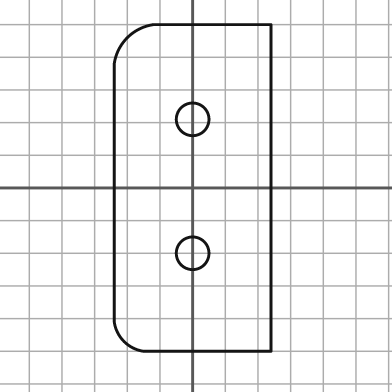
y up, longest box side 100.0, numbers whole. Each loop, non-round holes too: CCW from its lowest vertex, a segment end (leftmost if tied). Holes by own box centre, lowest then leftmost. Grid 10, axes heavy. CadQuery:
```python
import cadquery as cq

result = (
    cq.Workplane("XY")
    .moveTo(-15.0, -50.0)
    .lineTo(24.0, -50.0)
    .lineTo(24.0, 50.0)
    .lineTo(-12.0, 50.0)
    .threePointArc((-20.0, 46.0), (-24.0, 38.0))
    .lineTo(-24.0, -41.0)
    .threePointArc((-21.0, -47.0), (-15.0, -50.0))
    .close()
    .moveTo(0.0, -20.0)
    .circle(5.0)
    .moveTo(0.0, 21.0)
    .circle(5.0)
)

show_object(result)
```